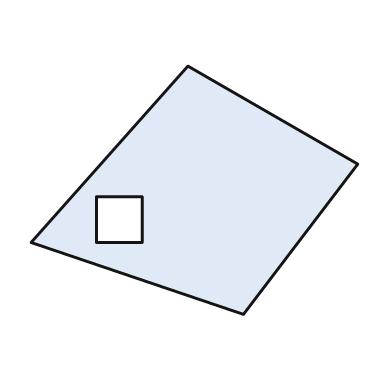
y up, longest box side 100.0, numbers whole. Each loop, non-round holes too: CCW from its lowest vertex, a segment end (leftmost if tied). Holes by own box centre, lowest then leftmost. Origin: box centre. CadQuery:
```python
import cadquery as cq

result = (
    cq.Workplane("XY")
    .moveTo(15.0, -38.0)
    .lineTo(50.0, 8.0)
    .lineTo(-2.0, 38.0)
    .lineTo(-50.0, -16.0)
    .close()
    .moveTo(-30.0, -16.0)
    .lineTo(-16.0, -16.0)
    .lineTo(-16.0, -2.0)
    .lineTo(-30.0, -2.0)
    .close()
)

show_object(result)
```